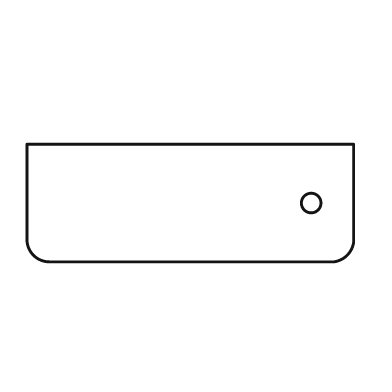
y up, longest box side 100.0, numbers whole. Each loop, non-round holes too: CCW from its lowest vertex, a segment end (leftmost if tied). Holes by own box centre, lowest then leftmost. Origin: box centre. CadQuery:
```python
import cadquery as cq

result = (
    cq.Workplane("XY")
    .moveTo(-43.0, -18.0)
    .lineTo(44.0, -18.0)
    .threePointArc((48.0, -16.0), (50.0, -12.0))
    .lineTo(50.0, 18.0)
    .lineTo(-50.0, 18.0)
    .lineTo(-50.0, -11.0)
    .threePointArc((-48.0, -16.0), (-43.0, -18.0))
    .close()
    .moveTo(37.0, 0.0)
    .circle(3.0)
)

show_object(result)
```